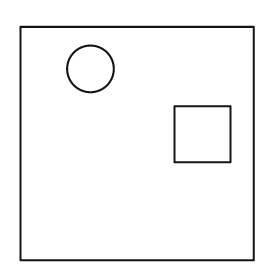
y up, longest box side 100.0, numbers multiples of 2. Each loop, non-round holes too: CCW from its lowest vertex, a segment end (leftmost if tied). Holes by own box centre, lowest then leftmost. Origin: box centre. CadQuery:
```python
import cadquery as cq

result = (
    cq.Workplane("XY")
    .moveTo(-50.0, -50.0)
    .lineTo(50.0, -50.0)
    .lineTo(50.0, 50.0)
    .lineTo(-50.0, 50.0)
    .close()
    .moveTo(16.0, -8.0)
    .lineTo(40.0, -8.0)
    .lineTo(40.0, 16.0)
    .lineTo(16.0, 16.0)
    .close()
    .moveTo(-20.0, 32.0)
    .circle(10.0)
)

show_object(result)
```